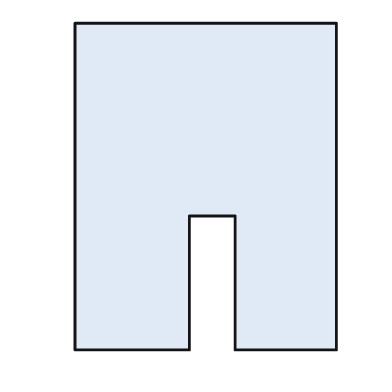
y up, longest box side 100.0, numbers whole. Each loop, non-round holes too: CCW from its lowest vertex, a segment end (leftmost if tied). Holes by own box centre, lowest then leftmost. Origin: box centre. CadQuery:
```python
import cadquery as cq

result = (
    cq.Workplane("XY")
    .moveTo(-40.0, -50.0)
    .lineTo(-5.0, -50.0)
    .lineTo(-5.0, -9.0)
    .lineTo(9.0, -9.0)
    .lineTo(9.0, -50.0)
    .lineTo(40.0, -50.0)
    .lineTo(40.0, 50.0)
    .lineTo(-40.0, 50.0)
    .close()
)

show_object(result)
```